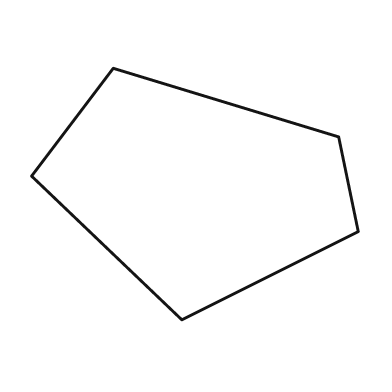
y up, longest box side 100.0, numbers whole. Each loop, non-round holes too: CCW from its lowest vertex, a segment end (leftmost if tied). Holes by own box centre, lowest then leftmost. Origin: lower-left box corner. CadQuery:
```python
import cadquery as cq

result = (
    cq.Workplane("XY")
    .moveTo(46.0, 0.0)
    .lineTo(100.0, 27.0)
    .lineTo(94.0, 56.0)
    .lineTo(25.0, 77.0)
    .lineTo(0.0, 44.0)
    .close()
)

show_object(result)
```